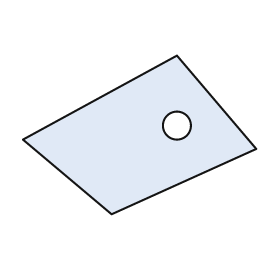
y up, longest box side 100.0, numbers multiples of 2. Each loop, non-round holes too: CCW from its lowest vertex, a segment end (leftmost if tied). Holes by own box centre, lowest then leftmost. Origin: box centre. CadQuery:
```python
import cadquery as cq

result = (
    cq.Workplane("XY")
    .moveTo(-12.0, -34.0)
    .lineTo(50.0, -6.0)
    .lineTo(16.0, 34.0)
    .lineTo(-50.0, -2.0)
    .close()
    .moveTo(16.0, 4.0)
    .circle(6.0)
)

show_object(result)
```